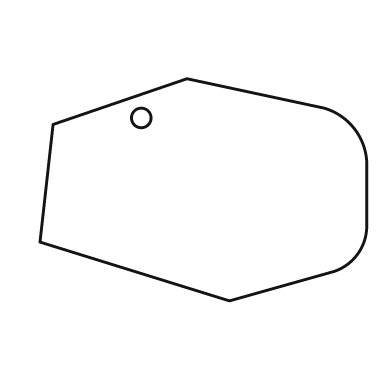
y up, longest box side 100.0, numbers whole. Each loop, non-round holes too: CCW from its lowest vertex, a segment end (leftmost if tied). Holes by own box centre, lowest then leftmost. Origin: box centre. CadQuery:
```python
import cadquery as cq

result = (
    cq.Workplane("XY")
    .moveTo(8.0, -34.0)
    .lineTo(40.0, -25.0)
    .threePointArc((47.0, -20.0), (50.0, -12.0))
    .lineTo(50.0, 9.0)
    .threePointArc((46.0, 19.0), (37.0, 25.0))
    .lineTo(-5.0, 34.0)
    .lineTo(-46.0, 20.0)
    .lineTo(-50.0, -16.0)
    .close()
    .moveTo(-19.0, 22.0)
    .circle(3.0)
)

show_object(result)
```